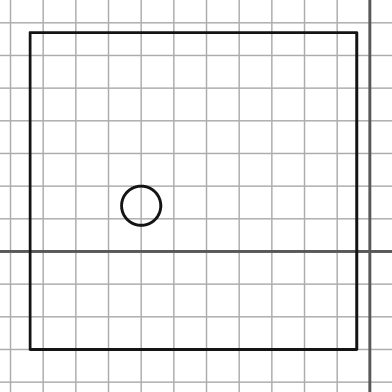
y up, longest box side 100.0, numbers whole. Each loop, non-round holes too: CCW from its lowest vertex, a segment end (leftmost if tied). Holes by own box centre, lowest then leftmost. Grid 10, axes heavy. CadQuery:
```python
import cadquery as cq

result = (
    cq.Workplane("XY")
    .moveTo(-104.0, -30.0)
    .lineTo(-4.0, -30.0)
    .lineTo(-4.0, 67.0)
    .lineTo(-104.0, 67.0)
    .close()
    .moveTo(-70.0, 14.0)
    .circle(6.0)
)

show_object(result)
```